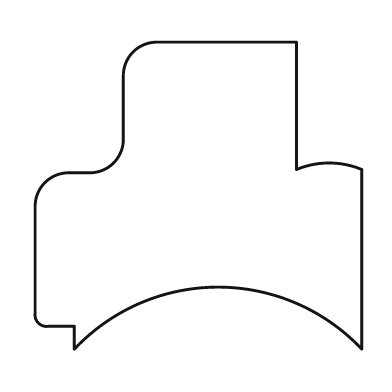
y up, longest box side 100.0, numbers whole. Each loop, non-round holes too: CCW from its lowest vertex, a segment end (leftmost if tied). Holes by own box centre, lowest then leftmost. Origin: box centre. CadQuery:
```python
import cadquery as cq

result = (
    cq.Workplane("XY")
    .moveTo(-38.0, -47.0)
    .threePointArc((6.0, -28.0), (50.0, -47.0))
    .lineTo(50.0, 8.0)
    .threePointArc((40.0, 10.0), (30.0, 8.0))
    .lineTo(30.0, 47.0)
    .lineTo(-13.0, 47.0)
    .threePointArc((-20.0, 44.0), (-23.0, 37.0))
    .lineTo(-23.0, 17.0)
    .threePointArc((-26.0, 10.0), (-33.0, 7.0))
    .lineTo(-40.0, 7.0)
    .threePointArc((-47.0, 4.0), (-50.0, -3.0))
    .lineTo(-50.0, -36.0)
    .threePointArc((-49.0, -39.0), (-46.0, -40.0))
    .lineTo(-38.0, -40.0)
    .close()
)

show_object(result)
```